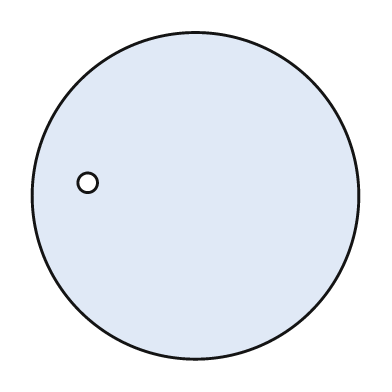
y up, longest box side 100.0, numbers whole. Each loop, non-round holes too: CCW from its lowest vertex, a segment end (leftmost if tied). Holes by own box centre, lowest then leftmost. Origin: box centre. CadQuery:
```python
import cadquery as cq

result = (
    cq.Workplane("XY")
    .moveTo(0.0, 0.0)
    .circle(50.0)
    .moveTo(-33.0, 4.0)
    .circle(3.0)
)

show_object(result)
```